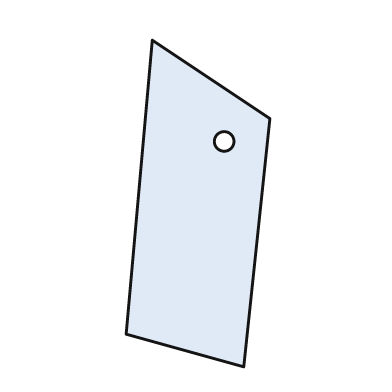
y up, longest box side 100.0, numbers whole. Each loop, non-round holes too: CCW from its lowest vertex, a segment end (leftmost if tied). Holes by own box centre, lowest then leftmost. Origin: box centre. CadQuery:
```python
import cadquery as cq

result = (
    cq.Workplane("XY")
    .moveTo(14.0, -50.0)
    .lineTo(22.0, 26.0)
    .lineTo(-14.0, 50.0)
    .lineTo(-22.0, -40.0)
    .close()
    .moveTo(8.0, 19.0)
    .circle(3.0)
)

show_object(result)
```